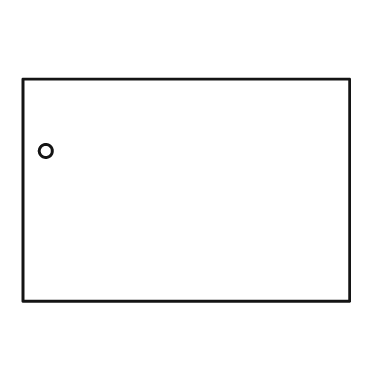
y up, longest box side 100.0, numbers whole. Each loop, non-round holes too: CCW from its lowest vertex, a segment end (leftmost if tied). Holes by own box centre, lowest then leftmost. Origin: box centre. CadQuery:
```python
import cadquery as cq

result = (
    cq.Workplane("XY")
    .moveTo(-50.0, -34.0)
    .lineTo(50.0, -34.0)
    .lineTo(50.0, 34.0)
    .lineTo(-50.0, 34.0)
    .close()
    .moveTo(-43.0, 12.0)
    .circle(2.0)
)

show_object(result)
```